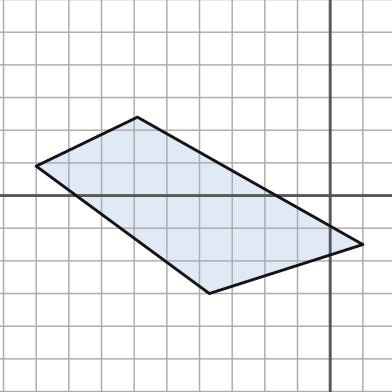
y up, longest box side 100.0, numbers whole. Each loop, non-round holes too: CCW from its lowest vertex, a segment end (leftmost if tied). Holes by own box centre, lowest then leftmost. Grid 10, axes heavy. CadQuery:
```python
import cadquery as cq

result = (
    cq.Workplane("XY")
    .moveTo(-37.0, -30.0)
    .lineTo(10.0, -15.0)
    .lineTo(-59.0, 24.0)
    .lineTo(-90.0, 9.0)
    .close()
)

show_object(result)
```